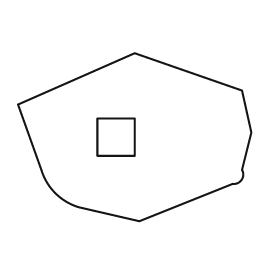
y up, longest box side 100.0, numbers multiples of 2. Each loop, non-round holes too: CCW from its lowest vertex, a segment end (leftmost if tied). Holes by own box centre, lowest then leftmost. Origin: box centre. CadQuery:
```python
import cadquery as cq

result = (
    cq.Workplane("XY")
    .moveTo(2.0, -36.0)
    .lineTo(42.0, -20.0)
    .threePointArc((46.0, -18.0), (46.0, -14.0))
    .lineTo(50.0, 2.0)
    .lineTo(46.0, 20.0)
    .lineTo(0.0, 36.0)
    .lineTo(-50.0, 14.0)
    .lineTo(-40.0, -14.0)
    .threePointArc((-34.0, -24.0), (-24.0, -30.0))
    .close()
    .moveTo(-16.0, -8.0)
    .lineTo(0.0, -8.0)
    .lineTo(0.0, 8.0)
    .lineTo(-16.0, 8.0)
    .close()
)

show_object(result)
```